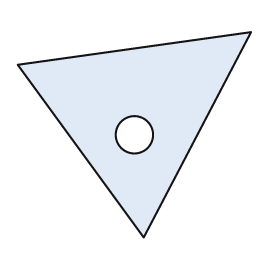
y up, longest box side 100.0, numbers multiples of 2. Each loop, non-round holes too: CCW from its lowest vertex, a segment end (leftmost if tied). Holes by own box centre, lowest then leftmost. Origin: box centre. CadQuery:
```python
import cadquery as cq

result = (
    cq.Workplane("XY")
    .moveTo(4.0, -44.0)
    .lineTo(50.0, 44.0)
    .lineTo(-50.0, 30.0)
    .close()
    .moveTo(0.0, 0.0)
    .circle(8.0)
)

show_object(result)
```